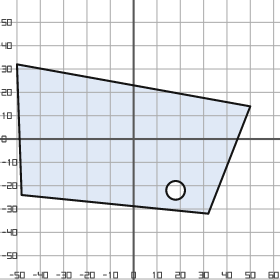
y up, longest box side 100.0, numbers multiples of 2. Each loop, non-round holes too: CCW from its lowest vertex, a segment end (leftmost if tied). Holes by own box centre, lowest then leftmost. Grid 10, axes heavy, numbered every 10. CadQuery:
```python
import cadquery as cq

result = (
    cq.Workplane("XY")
    .moveTo(32.0, -32.0)
    .lineTo(50.0, 14.0)
    .lineTo(-50.0, 32.0)
    .lineTo(-48.0, -24.0)
    .close()
    .moveTo(18.0, -22.0)
    .circle(4.0)
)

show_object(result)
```